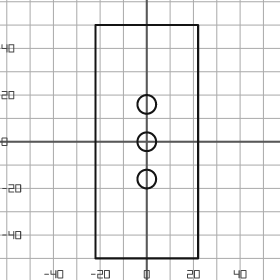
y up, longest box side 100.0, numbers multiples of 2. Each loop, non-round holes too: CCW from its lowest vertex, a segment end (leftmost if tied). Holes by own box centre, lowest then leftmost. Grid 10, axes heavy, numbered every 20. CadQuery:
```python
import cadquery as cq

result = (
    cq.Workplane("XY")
    .moveTo(-22.0, -50.0)
    .lineTo(22.0, -50.0)
    .lineTo(22.0, 50.0)
    .lineTo(-22.0, 50.0)
    .close()
    .moveTo(0.0, -16.0)
    .circle(4.0)
    .moveTo(0.0, 0.0)
    .circle(4.0)
    .moveTo(0.0, 16.0)
    .circle(4.0)
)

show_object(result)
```